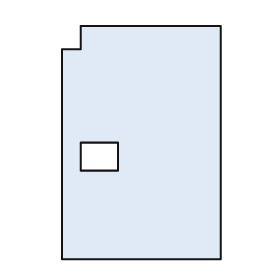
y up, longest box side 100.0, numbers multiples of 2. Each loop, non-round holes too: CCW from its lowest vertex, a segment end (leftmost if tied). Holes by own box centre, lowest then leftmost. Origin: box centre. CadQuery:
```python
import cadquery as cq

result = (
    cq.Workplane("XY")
    .moveTo(-34.0, -50.0)
    .lineTo(34.0, -50.0)
    .lineTo(34.0, 50.0)
    .lineTo(-26.0, 50.0)
    .lineTo(-26.0, 40.0)
    .lineTo(-34.0, 40.0)
    .close()
    .moveTo(-26.0, -12.0)
    .lineTo(-10.0, -12.0)
    .lineTo(-10.0, 0.0)
    .lineTo(-26.0, 0.0)
    .close()
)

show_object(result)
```